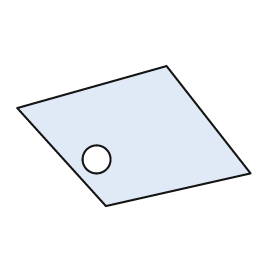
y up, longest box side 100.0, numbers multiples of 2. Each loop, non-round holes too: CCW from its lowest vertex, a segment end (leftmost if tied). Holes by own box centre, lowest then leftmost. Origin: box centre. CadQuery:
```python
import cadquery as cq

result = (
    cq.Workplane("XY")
    .moveTo(-12.0, -30.0)
    .lineTo(50.0, -16.0)
    .lineTo(14.0, 30.0)
    .lineTo(-50.0, 12.0)
    .close()
    .moveTo(-16.0, -10.0)
    .circle(6.0)
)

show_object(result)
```